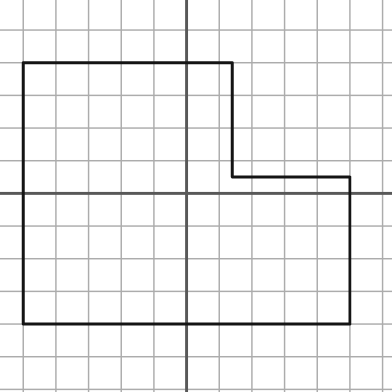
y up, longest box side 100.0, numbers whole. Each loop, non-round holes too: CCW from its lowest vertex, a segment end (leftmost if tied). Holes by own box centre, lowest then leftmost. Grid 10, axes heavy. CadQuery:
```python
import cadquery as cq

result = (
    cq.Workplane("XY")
    .moveTo(-50.0, -40.0)
    .lineTo(50.0, -40.0)
    .lineTo(50.0, 5.0)
    .lineTo(14.0, 5.0)
    .lineTo(14.0, 40.0)
    .lineTo(-50.0, 40.0)
    .close()
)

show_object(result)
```